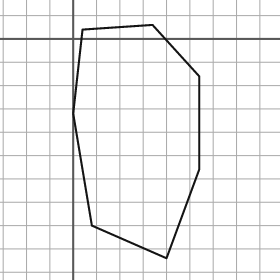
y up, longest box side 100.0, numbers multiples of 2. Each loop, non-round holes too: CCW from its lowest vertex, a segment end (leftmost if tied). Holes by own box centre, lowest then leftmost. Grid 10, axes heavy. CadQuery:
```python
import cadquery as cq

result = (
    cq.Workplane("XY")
    .moveTo(40.0, -94.0)
    .lineTo(54.0, -56.0)
    .lineTo(54.0, -16.0)
    .lineTo(34.0, 6.0)
    .lineTo(4.0, 4.0)
    .lineTo(0.0, -32.0)
    .lineTo(8.0, -80.0)
    .close()
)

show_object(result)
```